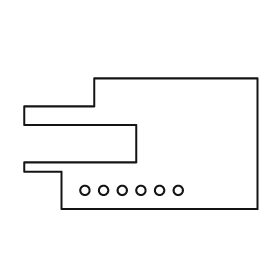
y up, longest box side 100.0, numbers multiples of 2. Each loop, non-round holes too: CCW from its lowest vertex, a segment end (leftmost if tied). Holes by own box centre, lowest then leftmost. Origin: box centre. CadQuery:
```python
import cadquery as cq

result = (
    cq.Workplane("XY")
    .moveTo(-34.0, -28.0)
    .lineTo(50.0, -28.0)
    .lineTo(50.0, 28.0)
    .lineTo(-20.0, 28.0)
    .lineTo(-20.0, 16.0)
    .lineTo(-50.0, 16.0)
    .lineTo(-50.0, 8.0)
    .lineTo(-2.0, 8.0)
    .lineTo(-2.0, -8.0)
    .lineTo(-50.0, -8.0)
    .lineTo(-50.0, -12.0)
    .lineTo(-34.0, -12.0)
    .close()
    .moveTo(-24.0, -20.0)
    .circle(2.0)
    .moveTo(-16.0, -20.0)
    .circle(2.0)
    .moveTo(-8.0, -20.0)
    .circle(2.0)
    .moveTo(0.0, -20.0)
    .circle(2.0)
    .moveTo(8.0, -20.0)
    .circle(2.0)
    .moveTo(16.0, -20.0)
    .circle(2.0)
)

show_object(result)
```